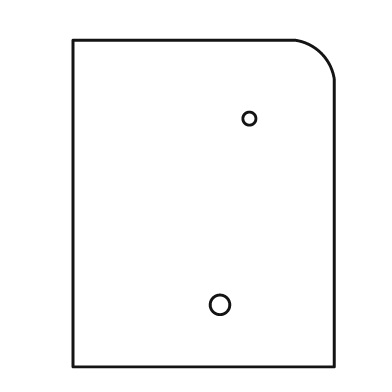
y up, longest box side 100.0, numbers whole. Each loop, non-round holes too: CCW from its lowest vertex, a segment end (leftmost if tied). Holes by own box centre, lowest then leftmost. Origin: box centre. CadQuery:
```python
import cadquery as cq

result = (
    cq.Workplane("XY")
    .moveTo(-40.0, -50.0)
    .lineTo(40.0, -50.0)
    .lineTo(40.0, 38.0)
    .threePointArc((36.0, 46.0), (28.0, 50.0))
    .lineTo(-40.0, 50.0)
    .close()
    .moveTo(5.0, -31.0)
    .circle(3.0)
    .moveTo(14.0, 26.0)
    .circle(2.0)
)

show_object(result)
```